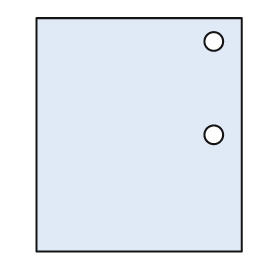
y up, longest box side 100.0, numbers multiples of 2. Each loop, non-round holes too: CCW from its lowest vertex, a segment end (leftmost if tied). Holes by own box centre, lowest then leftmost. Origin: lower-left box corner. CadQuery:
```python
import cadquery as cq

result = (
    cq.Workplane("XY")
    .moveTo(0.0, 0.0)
    .lineTo(88.0, 0.0)
    .lineTo(88.0, 100.0)
    .lineTo(0.0, 100.0)
    .close()
    .moveTo(76.0, 50.0)
    .circle(4.0)
    .moveTo(76.0, 90.0)
    .circle(4.0)
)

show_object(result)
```